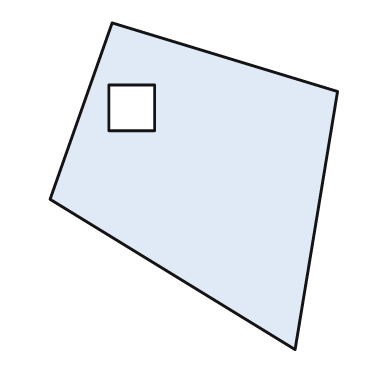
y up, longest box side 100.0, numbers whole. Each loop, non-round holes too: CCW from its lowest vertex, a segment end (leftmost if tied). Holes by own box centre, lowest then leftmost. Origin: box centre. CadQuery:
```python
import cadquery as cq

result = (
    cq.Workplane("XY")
    .moveTo(31.0, -50.0)
    .lineTo(44.0, 29.0)
    .lineTo(-25.0, 50.0)
    .lineTo(-44.0, -4.0)
    .close()
    .moveTo(-26.0, 17.0)
    .lineTo(-12.0, 17.0)
    .lineTo(-12.0, 31.0)
    .lineTo(-26.0, 31.0)
    .close()
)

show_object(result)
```